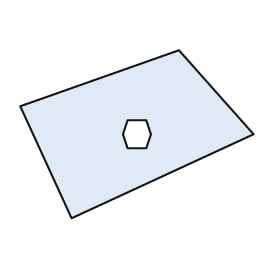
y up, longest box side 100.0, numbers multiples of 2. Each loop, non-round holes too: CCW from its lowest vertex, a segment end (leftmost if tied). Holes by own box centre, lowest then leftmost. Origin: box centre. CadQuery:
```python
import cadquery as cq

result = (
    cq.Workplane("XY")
    .moveTo(-28.0, -36.0)
    .lineTo(50.0, 0.0)
    .lineTo(18.0, 36.0)
    .lineTo(-50.0, 12.0)
    .close()
    .moveTo(-4.0, -6.0)
    .lineTo(4.0, -6.0)
    .lineTo(6.0, 0.0)
    .lineTo(4.0, 6.0)
    .lineTo(-4.0, 6.0)
    .lineTo(-6.0, 0.0)
    .close()
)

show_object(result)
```